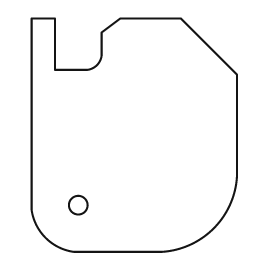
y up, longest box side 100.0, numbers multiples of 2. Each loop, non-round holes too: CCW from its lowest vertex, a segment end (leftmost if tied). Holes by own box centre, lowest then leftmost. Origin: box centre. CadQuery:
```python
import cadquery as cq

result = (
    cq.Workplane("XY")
    .moveTo(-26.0, -50.0)
    .lineTo(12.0, -50.0)
    .threePointArc((34.0, -40.0), (44.0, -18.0))
    .lineTo(44.0, 26.0)
    .lineTo(20.0, 50.0)
    .lineTo(-6.0, 50.0)
    .lineTo(-14.0, 44.0)
    .lineTo(-14.0, 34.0)
    .threePointArc((-16.0, 30.0), (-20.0, 28.0))
    .lineTo(-34.0, 28.0)
    .lineTo(-34.0, 50.0)
    .lineTo(-44.0, 50.0)
    .lineTo(-44.0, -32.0)
    .threePointArc((-38.0, -44.0), (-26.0, -50.0))
    .close()
    .moveTo(-24.0, -30.0)
    .circle(4.0)
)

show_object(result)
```